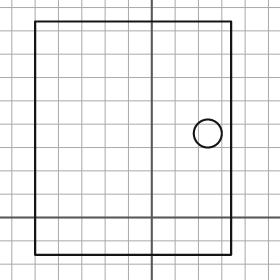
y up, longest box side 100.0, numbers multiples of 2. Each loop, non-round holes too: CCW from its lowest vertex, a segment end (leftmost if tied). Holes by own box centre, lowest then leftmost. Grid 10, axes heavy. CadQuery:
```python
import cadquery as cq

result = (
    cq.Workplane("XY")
    .moveTo(-50.0, -16.0)
    .lineTo(34.0, -16.0)
    .lineTo(34.0, 84.0)
    .lineTo(-50.0, 84.0)
    .close()
    .moveTo(24.0, 36.0)
    .circle(6.0)
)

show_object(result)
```